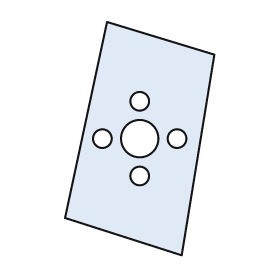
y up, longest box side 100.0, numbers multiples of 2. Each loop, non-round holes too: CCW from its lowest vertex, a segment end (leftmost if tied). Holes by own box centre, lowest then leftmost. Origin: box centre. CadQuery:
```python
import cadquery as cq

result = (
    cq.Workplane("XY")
    .moveTo(18.0, -50.0)
    .lineTo(32.0, 36.0)
    .lineTo(-14.0, 50.0)
    .lineTo(-32.0, -34.0)
    .close()
    .moveTo(0.0, -16.0)
    .circle(4.0)
    .moveTo(-16.0, 0.0)
    .circle(4.0)
    .moveTo(0.0, 0.0)
    .circle(8.0)
    .moveTo(16.0, 0.0)
    .circle(4.0)
    .moveTo(0.0, 16.0)
    .circle(4.0)
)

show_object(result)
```